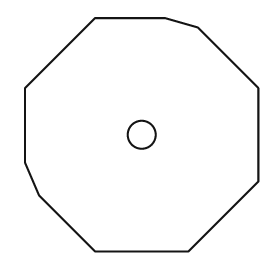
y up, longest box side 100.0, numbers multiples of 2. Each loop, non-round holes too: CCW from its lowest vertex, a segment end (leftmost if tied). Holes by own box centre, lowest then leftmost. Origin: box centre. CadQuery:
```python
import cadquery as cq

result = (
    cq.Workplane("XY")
    .moveTo(-20.0, -50.0)
    .lineTo(20.0, -50.0)
    .lineTo(50.0, -20.0)
    .lineTo(50.0, 20.0)
    .lineTo(24.0, 46.0)
    .lineTo(10.0, 50.0)
    .lineTo(-20.0, 50.0)
    .lineTo(-50.0, 20.0)
    .lineTo(-50.0, -12.0)
    .lineTo(-44.0, -26.0)
    .close()
    .moveTo(0.0, 0.0)
    .circle(6.0)
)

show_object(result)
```